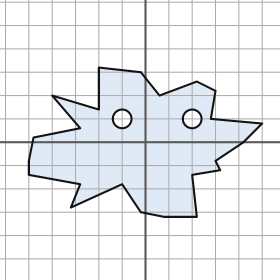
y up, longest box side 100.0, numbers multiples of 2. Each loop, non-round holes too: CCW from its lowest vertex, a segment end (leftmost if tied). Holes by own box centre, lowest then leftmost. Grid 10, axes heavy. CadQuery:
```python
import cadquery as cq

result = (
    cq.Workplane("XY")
    .moveTo(8.0, -32.0)
    .lineTo(22.0, -32.0)
    .lineTo(20.0, -14.0)
    .lineTo(32.0, -12.0)
    .lineTo(30.0, -8.0)
    .lineTo(42.0, 0.0)
    .lineTo(50.0, 8.0)
    .lineTo(28.0, 10.0)
    .lineTo(30.0, 22.0)
    .lineTo(22.0, 26.0)
    .lineTo(6.0, 20.0)
    .lineTo(-2.0, 30.0)
    .lineTo(-20.0, 32.0)
    .lineTo(-20.0, 14.0)
    .lineTo(-40.0, 20.0)
    .lineTo(-28.0, 6.0)
    .lineTo(-48.0, 2.0)
    .lineTo(-50.0, -8.0)
    .lineTo(-50.0, -14.0)
    .lineTo(-28.0, -18.0)
    .lineTo(-32.0, -28.0)
    .lineTo(-10.0, -18.0)
    .lineTo(-2.0, -30.0)
    .close()
    .moveTo(-10.0, 10.0)
    .circle(4.0)
    .moveTo(20.0, 10.0)
    .circle(4.0)
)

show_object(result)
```